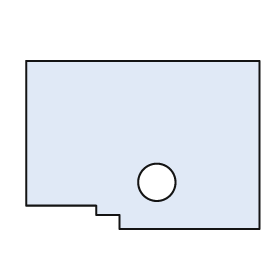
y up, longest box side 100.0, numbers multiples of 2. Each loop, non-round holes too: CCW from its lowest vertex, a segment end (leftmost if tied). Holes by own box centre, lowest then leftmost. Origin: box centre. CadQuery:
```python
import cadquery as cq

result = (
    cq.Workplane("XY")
    .moveTo(-10.0, -36.0)
    .lineTo(50.0, -36.0)
    .lineTo(50.0, 36.0)
    .lineTo(-50.0, 36.0)
    .lineTo(-50.0, -26.0)
    .lineTo(-20.0, -26.0)
    .lineTo(-20.0, -30.0)
    .lineTo(-10.0, -30.0)
    .close()
    .moveTo(6.0, -16.0)
    .circle(8.0)
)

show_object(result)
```